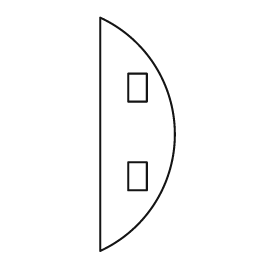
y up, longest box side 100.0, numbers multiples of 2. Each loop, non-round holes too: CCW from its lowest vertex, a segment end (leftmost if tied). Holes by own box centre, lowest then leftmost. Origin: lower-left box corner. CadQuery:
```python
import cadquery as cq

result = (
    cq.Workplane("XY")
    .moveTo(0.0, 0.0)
    .threePointArc((32.0, 50.0), (0.0, 100.0))
    .close()
    .moveTo(12.0, 26.0)
    .lineTo(20.0, 26.0)
    .lineTo(20.0, 38.0)
    .lineTo(12.0, 38.0)
    .close()
    .moveTo(12.0, 64.0)
    .lineTo(20.0, 64.0)
    .lineTo(20.0, 76.0)
    .lineTo(12.0, 76.0)
    .close()
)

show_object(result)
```